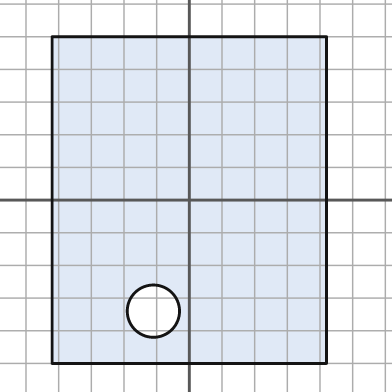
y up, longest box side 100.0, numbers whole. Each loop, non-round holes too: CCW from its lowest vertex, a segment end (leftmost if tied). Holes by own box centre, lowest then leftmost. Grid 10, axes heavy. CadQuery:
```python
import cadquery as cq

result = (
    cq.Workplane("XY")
    .moveTo(-42.0, -50.0)
    .lineTo(42.0, -50.0)
    .lineTo(42.0, 50.0)
    .lineTo(-42.0, 50.0)
    .close()
    .moveTo(-11.0, -34.0)
    .circle(8.0)
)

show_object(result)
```